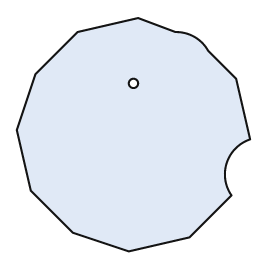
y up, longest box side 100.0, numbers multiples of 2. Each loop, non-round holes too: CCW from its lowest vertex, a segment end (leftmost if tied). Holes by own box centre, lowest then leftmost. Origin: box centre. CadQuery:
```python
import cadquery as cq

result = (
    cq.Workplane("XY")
    .moveTo(-2.0, -50.0)
    .lineTo(24.0, -44.0)
    .lineTo(42.0, -26.0)
    .threePointArc((40.0, -12.0), (50.0, -2.0))
    .lineTo(44.0, 24.0)
    .lineTo(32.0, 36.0)
    .threePointArc((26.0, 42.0), (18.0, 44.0))
    .lineTo(2.0, 50.0)
    .lineTo(-24.0, 44.0)
    .lineTo(-42.0, 26.0)
    .lineTo(-50.0, 2.0)
    .lineTo(-44.0, -24.0)
    .lineTo(-26.0, -42.0)
    .close()
    .moveTo(0.0, 22.0)
    .circle(2.0)
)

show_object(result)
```